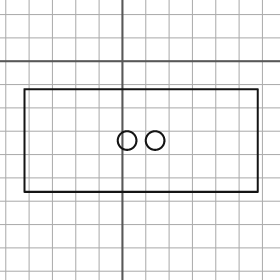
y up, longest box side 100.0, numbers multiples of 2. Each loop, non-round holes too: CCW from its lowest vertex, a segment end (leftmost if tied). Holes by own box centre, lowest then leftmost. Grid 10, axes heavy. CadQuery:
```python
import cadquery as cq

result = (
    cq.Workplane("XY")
    .moveTo(-42.0, -56.0)
    .lineTo(58.0, -56.0)
    .lineTo(58.0, -12.0)
    .lineTo(-42.0, -12.0)
    .close()
    .moveTo(2.0, -34.0)
    .circle(4.0)
    .moveTo(14.0, -34.0)
    .circle(4.0)
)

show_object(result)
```